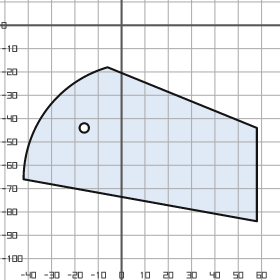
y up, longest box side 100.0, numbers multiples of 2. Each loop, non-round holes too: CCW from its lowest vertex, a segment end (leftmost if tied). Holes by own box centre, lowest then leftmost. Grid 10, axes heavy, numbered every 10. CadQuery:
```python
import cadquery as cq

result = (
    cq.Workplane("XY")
    .moveTo(58.0, -84.0)
    .lineTo(58.0, -44.0)
    .lineTo(-6.0, -18.0)
    .threePointArc((-32.0, -36.0), (-42.0, -66.0))
    .close()
    .moveTo(-16.0, -44.0)
    .circle(2.0)
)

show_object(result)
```